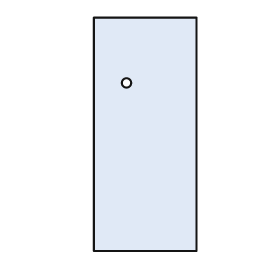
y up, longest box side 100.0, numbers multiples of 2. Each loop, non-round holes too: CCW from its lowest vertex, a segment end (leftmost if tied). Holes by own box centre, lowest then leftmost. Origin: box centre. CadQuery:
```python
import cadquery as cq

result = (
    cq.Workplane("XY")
    .moveTo(-22.0, -50.0)
    .lineTo(22.0, -50.0)
    .lineTo(22.0, 50.0)
    .lineTo(-22.0, 50.0)
    .close()
    .moveTo(-8.0, 22.0)
    .circle(2.0)
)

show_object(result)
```